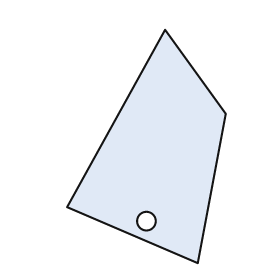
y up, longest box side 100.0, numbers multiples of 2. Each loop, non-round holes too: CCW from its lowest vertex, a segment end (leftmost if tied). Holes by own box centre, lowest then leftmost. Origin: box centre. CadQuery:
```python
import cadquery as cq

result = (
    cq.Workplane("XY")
    .moveTo(22.0, -50.0)
    .lineTo(34.0, 14.0)
    .lineTo(8.0, 50.0)
    .lineTo(-34.0, -26.0)
    .close()
    .moveTo(0.0, -32.0)
    .circle(4.0)
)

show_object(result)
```